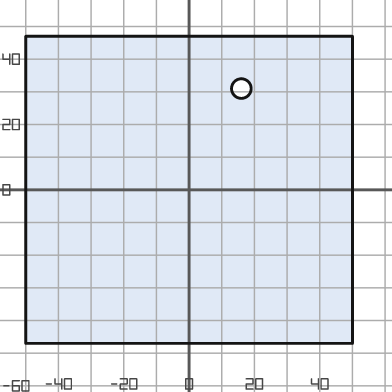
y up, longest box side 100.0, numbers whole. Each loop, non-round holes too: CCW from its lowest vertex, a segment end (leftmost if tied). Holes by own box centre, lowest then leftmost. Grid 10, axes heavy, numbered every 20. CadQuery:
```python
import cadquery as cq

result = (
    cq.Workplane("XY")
    .moveTo(-50.0, -47.0)
    .lineTo(50.0, -47.0)
    .lineTo(50.0, 47.0)
    .lineTo(-50.0, 47.0)
    .close()
    .moveTo(16.0, 31.0)
    .circle(3.0)
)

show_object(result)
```